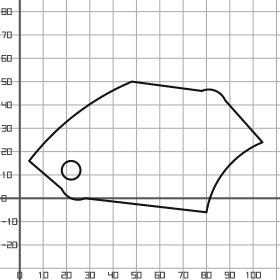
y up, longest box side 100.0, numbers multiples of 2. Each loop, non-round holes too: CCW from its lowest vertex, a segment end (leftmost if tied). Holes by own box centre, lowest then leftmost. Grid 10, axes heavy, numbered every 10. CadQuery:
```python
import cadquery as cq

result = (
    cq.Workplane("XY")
    .moveTo(80.0, -6.0)
    .threePointArc((88.0, 12.0), (104.0, 24.0))
    .lineTo(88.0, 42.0)
    .threePointArc((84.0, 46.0), (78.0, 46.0))
    .lineTo(48.0, 50.0)
    .threePointArc((24.0, 36.0), (4.0, 16.0))
    .lineTo(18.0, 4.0)
    .threePointArc((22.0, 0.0), (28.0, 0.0))
    .close()
    .moveTo(22.0, 12.0)
    .circle(4.0)
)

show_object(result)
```